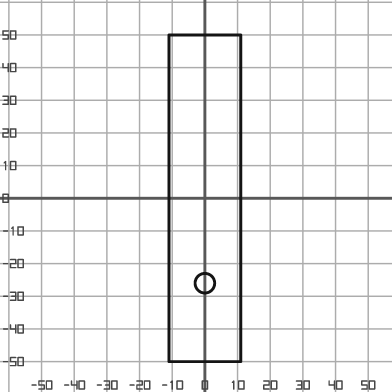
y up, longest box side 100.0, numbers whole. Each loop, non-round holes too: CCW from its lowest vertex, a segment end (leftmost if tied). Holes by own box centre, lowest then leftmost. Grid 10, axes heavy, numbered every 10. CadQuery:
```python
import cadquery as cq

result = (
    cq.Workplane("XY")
    .moveTo(-11.0, -50.0)
    .lineTo(11.0, -50.0)
    .lineTo(11.0, 50.0)
    .lineTo(-11.0, 50.0)
    .close()
    .moveTo(0.0, -26.0)
    .circle(3.0)
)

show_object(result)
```